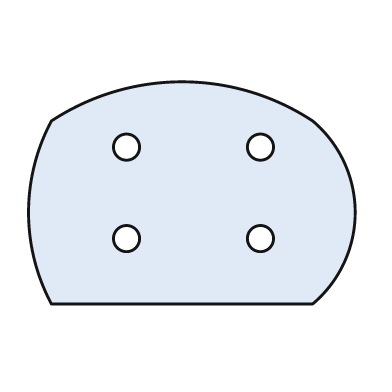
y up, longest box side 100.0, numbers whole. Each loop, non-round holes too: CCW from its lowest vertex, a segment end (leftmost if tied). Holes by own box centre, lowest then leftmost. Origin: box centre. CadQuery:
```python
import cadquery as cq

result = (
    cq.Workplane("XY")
    .moveTo(-43.0, -34.0)
    .lineTo(37.0, -34.0)
    .threePointArc((50.0, -6.0), (37.0, 22.0))
    .threePointArc((-3.0, 34.0), (-43.0, 22.0))
    .threePointArc((-50.0, -6.0), (-43.0, -34.0))
    .close()
    .moveTo(-20.0, -14.0)
    .circle(4.0)
    .moveTo(21.0, -14.0)
    .circle(4.0)
    .moveTo(-20.0, 14.0)
    .circle(4.0)
    .moveTo(21.0, 14.0)
    .circle(4.0)
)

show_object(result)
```